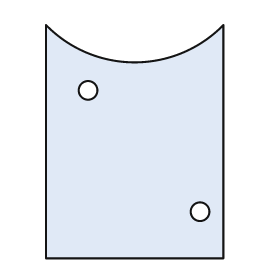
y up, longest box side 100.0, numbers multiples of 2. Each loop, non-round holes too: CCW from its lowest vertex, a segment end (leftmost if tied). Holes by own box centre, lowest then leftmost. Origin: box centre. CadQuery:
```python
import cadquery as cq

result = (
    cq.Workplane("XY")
    .moveTo(-38.0, -50.0)
    .lineTo(38.0, -50.0)
    .lineTo(38.0, 50.0)
    .threePointArc((0.0, 34.0), (-38.0, 50.0))
    .close()
    .moveTo(28.0, -30.0)
    .circle(4.0)
    .moveTo(-20.0, 22.0)
    .circle(4.0)
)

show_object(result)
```